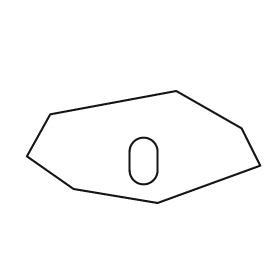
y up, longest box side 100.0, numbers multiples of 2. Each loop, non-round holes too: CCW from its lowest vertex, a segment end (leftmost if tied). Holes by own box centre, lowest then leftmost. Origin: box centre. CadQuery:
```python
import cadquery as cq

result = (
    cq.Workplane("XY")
    .moveTo(6.0, -24.0)
    .lineTo(50.0, -8.0)
    .lineTo(42.0, 8.0)
    .lineTo(14.0, 24.0)
    .lineTo(-40.0, 14.0)
    .lineTo(-50.0, -4.0)
    .lineTo(-30.0, -18.0)
    .close()
    .moveTo(-6.0, -10.0)
    .threePointArc((0.0, -16.0), (6.0, -10.0))
    .lineTo(6.0, -2.0)
    .threePointArc((0.0, 4.0), (-6.0, -2.0))
    .close()
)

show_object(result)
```